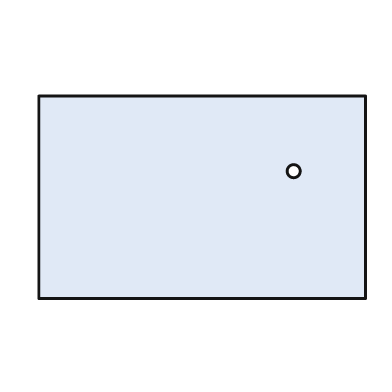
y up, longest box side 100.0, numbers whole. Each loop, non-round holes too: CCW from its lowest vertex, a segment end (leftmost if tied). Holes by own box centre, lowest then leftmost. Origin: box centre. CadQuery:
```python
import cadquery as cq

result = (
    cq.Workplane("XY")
    .moveTo(-50.0, -31.0)
    .lineTo(50.0, -31.0)
    .lineTo(50.0, 31.0)
    .lineTo(-50.0, 31.0)
    .close()
    .moveTo(28.0, 8.0)
    .circle(2.0)
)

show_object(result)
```